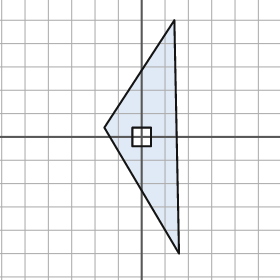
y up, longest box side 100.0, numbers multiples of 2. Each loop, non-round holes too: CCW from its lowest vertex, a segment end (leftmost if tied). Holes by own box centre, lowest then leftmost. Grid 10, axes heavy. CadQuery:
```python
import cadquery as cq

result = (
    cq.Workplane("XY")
    .moveTo(16.0, -50.0)
    .lineTo(14.0, 50.0)
    .lineTo(-16.0, 4.0)
    .close()
    .moveTo(-4.0, -4.0)
    .lineTo(4.0, -4.0)
    .lineTo(4.0, 4.0)
    .lineTo(-4.0, 4.0)
    .close()
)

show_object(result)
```